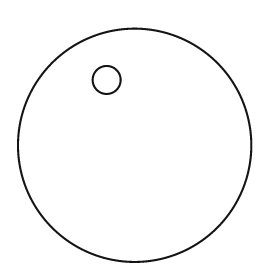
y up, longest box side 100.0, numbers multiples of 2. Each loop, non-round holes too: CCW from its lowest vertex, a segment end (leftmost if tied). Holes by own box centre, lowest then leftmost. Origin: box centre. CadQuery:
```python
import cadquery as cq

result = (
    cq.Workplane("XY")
    .moveTo(0.0, 0.0)
    .circle(50.0)
    .moveTo(-12.0, 28.0)
    .circle(6.0)
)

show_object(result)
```